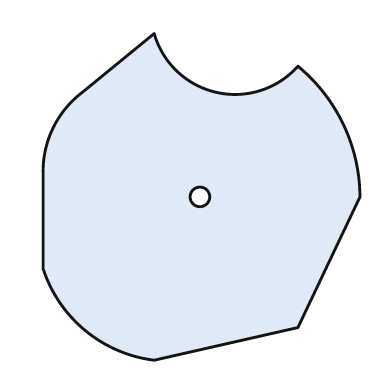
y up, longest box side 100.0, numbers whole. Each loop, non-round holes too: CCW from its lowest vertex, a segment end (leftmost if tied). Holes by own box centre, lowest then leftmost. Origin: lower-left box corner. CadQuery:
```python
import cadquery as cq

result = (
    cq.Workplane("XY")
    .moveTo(34.0, 0.0)
    .lineTo(78.0, 10.0)
    .lineTo(97.0, 50.0)
    .threePointArc((92.0, 72.0), (78.0, 90.0))
    .threePointArc((53.0, 82.0), (34.0, 100.0))
    .lineTo(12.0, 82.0)
    .threePointArc((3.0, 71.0), (0.0, 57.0))
    .lineTo(0.0, 28.0)
    .threePointArc((13.0, 9.0), (34.0, 0.0))
    .close()
    .moveTo(48.0, 50.0)
    .circle(3.0)
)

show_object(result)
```